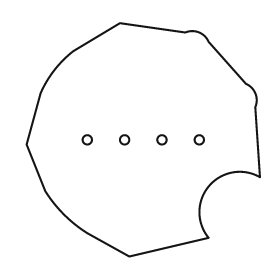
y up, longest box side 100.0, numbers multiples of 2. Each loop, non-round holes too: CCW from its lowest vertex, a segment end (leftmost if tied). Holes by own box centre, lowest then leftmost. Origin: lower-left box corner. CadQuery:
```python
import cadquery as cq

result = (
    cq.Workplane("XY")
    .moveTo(44.0, 0.0)
    .lineTo(78.0, 8.0)
    .threePointArc((78.0, 30.0), (100.0, 34.0))
    .lineTo(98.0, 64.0)
    .threePointArc((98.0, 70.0), (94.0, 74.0))
    .lineTo(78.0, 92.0)
    .threePointArc((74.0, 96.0), (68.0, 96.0))
    .lineTo(40.0, 100.0)
    .lineTo(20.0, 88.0)
    .threePointArc((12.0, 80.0), (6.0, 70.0))
    .lineTo(0.0, 48.0)
    .lineTo(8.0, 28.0)
    .threePointArc((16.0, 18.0), (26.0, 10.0))
    .close()
    .moveTo(26.0, 50.0)
    .circle(2.0)
    .moveTo(42.0, 50.0)
    .circle(2.0)
    .moveTo(58.0, 50.0)
    .circle(2.0)
    .moveTo(74.0, 50.0)
    .circle(2.0)
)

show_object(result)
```